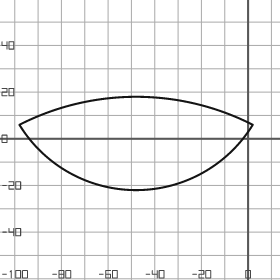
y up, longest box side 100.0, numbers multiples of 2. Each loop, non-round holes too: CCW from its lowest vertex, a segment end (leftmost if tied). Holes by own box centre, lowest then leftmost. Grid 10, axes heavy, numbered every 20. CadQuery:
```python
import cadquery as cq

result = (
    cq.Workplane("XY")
    .moveTo(-98.0, 6.0)
    .threePointArc((-48.0, -22.0), (2.0, 6.0))
    .threePointArc((-48.0, 18.0), (-98.0, 6.0))
    .close()
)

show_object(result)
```